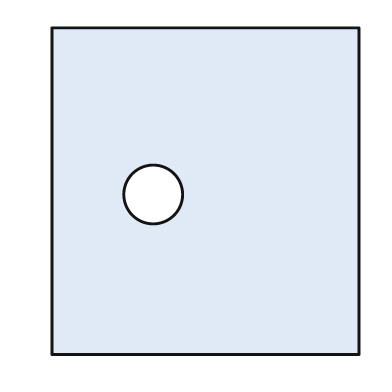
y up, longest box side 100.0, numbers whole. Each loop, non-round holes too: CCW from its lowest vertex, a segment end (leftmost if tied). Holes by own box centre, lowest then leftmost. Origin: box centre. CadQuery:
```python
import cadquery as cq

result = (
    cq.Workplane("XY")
    .moveTo(-47.0, -50.0)
    .lineTo(47.0, -50.0)
    .lineTo(47.0, 50.0)
    .lineTo(-47.0, 50.0)
    .close()
    .moveTo(-16.0, -1.0)
    .circle(9.0)
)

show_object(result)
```